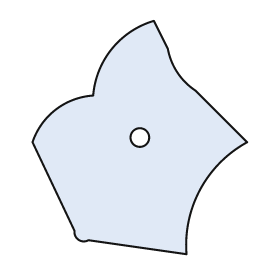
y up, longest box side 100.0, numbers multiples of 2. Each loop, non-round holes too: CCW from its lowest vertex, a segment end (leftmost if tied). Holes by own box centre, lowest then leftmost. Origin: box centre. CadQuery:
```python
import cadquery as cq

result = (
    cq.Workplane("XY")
    .moveTo(20.0, -50.0)
    .threePointArc((26.0, -22.0), (46.0, -2.0))
    .lineTo(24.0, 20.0)
    .threePointArc((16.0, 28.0), (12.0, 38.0))
    .lineTo(6.0, 50.0)
    .threePointArc((-12.0, 38.0), (-20.0, 18.0))
    .threePointArc((-36.0, 12.0), (-46.0, -2.0))
    .lineTo(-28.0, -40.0)
    .threePointArc((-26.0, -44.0), (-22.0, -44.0))
    .close()
    .moveTo(0.0, 0.0)
    .circle(4.0)
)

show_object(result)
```